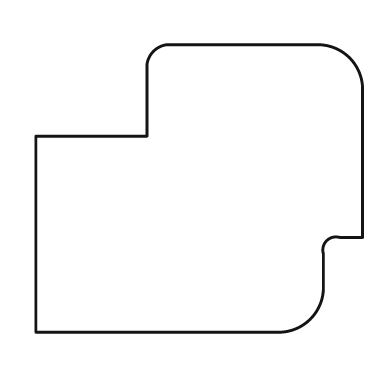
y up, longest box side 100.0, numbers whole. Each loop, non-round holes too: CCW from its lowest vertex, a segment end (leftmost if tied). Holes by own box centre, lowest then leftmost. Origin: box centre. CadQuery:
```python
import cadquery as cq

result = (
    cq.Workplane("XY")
    .moveTo(-50.0, -44.0)
    .lineTo(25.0, -44.0)
    .threePointArc((34.0, -40.0), (38.0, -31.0))
    .lineTo(38.0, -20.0)
    .threePointArc((39.0, -16.0), (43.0, -15.0))
    .lineTo(50.0, -15.0)
    .lineTo(50.0, 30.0)
    .threePointArc((46.0, 40.0), (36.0, 44.0))
    .lineTo(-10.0, 44.0)
    .threePointArc((-14.0, 42.0), (-16.0, 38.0))
    .lineTo(-16.0, 16.0)
    .lineTo(-50.0, 16.0)
    .close()
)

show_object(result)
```